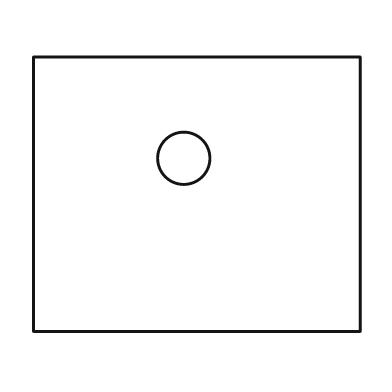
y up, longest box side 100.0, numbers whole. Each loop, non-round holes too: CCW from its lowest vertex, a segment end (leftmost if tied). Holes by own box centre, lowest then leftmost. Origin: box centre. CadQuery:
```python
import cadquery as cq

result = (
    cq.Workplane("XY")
    .moveTo(-50.0, -42.0)
    .lineTo(50.0, -42.0)
    .lineTo(50.0, 42.0)
    .lineTo(-50.0, 42.0)
    .close()
    .moveTo(-4.0, 11.0)
    .circle(8.0)
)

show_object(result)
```